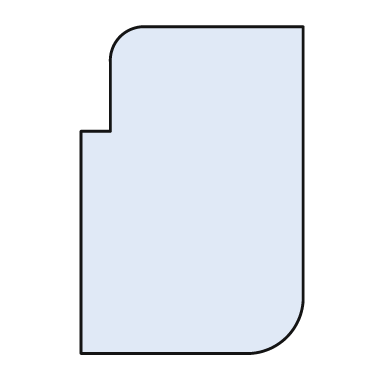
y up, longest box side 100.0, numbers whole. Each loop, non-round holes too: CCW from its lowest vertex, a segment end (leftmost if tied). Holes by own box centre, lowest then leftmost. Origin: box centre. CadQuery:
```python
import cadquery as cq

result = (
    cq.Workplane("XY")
    .moveTo(-34.0, -50.0)
    .lineTo(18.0, -50.0)
    .threePointArc((29.0, -45.0), (34.0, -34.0))
    .lineTo(34.0, 50.0)
    .lineTo(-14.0, 50.0)
    .threePointArc((-22.0, 47.0), (-25.0, 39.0))
    .lineTo(-25.0, 18.0)
    .lineTo(-34.0, 18.0)
    .close()
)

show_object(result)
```